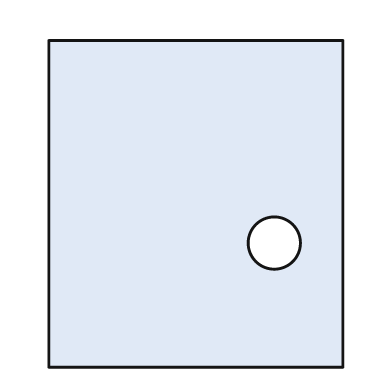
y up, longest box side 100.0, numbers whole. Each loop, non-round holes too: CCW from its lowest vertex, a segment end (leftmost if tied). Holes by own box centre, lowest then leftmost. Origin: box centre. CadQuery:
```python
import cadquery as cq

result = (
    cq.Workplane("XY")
    .moveTo(-45.0, -50.0)
    .lineTo(45.0, -50.0)
    .lineTo(45.0, 50.0)
    .lineTo(-45.0, 50.0)
    .close()
    .moveTo(24.0, -12.0)
    .circle(8.0)
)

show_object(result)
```